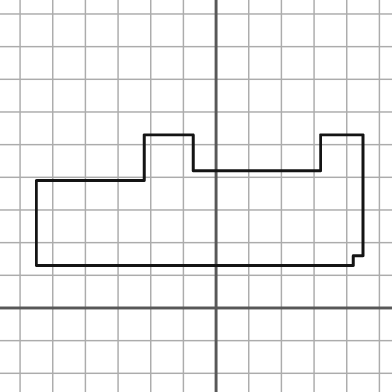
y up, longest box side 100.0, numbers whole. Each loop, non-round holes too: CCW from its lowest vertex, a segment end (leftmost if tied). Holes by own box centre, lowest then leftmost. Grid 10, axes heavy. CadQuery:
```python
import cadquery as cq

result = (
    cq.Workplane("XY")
    .moveTo(-55.0, 13.0)
    .lineTo(42.0, 13.0)
    .lineTo(42.0, 16.0)
    .lineTo(45.0, 16.0)
    .lineTo(45.0, 53.0)
    .lineTo(32.0, 53.0)
    .lineTo(32.0, 42.0)
    .lineTo(-7.0, 42.0)
    .lineTo(-7.0, 53.0)
    .lineTo(-22.0, 53.0)
    .lineTo(-22.0, 39.0)
    .lineTo(-55.0, 39.0)
    .close()
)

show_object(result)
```